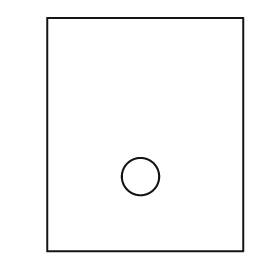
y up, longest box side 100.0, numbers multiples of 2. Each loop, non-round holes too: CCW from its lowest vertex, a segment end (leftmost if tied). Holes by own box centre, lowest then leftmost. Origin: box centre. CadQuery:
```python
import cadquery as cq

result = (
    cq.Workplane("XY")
    .moveTo(-42.0, -50.0)
    .lineTo(42.0, -50.0)
    .lineTo(42.0, 50.0)
    .lineTo(-42.0, 50.0)
    .close()
    .moveTo(-2.0, -18.0)
    .circle(8.0)
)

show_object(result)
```